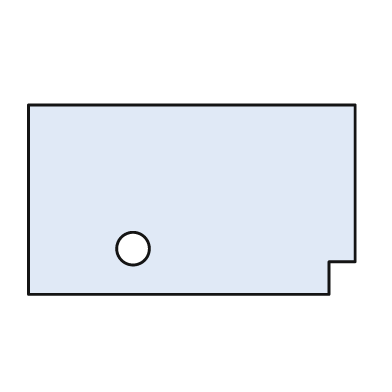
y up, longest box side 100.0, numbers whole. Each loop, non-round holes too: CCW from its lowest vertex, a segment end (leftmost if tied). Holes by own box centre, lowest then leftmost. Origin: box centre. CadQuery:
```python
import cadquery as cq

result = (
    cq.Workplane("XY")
    .moveTo(-50.0, -29.0)
    .lineTo(42.0, -29.0)
    .lineTo(42.0, -19.0)
    .lineTo(50.0, -19.0)
    .lineTo(50.0, 29.0)
    .lineTo(-50.0, 29.0)
    .close()
    .moveTo(-18.0, -15.0)
    .circle(5.0)
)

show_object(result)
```